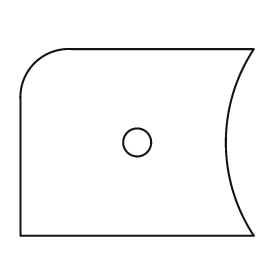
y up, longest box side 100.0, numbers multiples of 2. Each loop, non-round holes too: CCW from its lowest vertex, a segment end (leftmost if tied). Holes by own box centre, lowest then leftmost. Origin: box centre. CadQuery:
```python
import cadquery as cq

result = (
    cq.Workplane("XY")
    .moveTo(-50.0, -40.0)
    .lineTo(50.0, -40.0)
    .threePointArc((38.0, 0.0), (50.0, 40.0))
    .lineTo(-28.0, 40.0)
    .threePointArc((-44.0, 34.0), (-50.0, 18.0))
    .close()
    .moveTo(0.0, 0.0)
    .circle(6.0)
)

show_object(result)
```